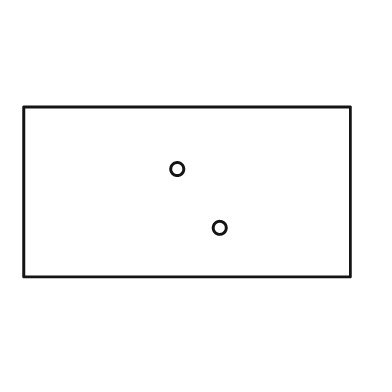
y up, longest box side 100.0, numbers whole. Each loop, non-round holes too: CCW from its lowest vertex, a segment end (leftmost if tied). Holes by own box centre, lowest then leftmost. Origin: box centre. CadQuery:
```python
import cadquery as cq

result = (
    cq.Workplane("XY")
    .moveTo(-50.0, -26.0)
    .lineTo(50.0, -26.0)
    .lineTo(50.0, 26.0)
    .lineTo(-50.0, 26.0)
    .close()
    .moveTo(10.0, -11.0)
    .circle(2.0)
    .moveTo(-3.0, 7.0)
    .circle(2.0)
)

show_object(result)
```